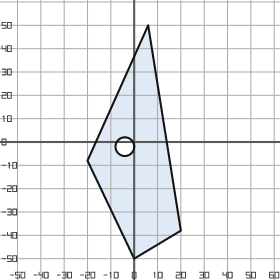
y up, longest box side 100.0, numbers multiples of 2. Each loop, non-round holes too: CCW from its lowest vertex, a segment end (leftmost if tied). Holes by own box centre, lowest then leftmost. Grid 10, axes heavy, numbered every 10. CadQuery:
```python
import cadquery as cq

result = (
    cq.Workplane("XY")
    .moveTo(0.0, -50.0)
    .lineTo(20.0, -38.0)
    .lineTo(6.0, 50.0)
    .lineTo(-20.0, -8.0)
    .close()
    .moveTo(-4.0, -2.0)
    .circle(4.0)
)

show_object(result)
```